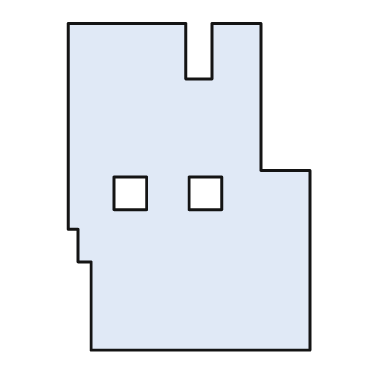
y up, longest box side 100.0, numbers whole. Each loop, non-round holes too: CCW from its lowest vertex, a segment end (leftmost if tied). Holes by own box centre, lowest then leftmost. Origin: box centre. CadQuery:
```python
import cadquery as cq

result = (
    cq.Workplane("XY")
    .moveTo(-30.0, -50.0)
    .lineTo(37.0, -50.0)
    .lineTo(37.0, 5.0)
    .lineTo(22.0, 5.0)
    .lineTo(22.0, 50.0)
    .lineTo(7.0, 50.0)
    .lineTo(7.0, 33.0)
    .lineTo(-1.0, 33.0)
    .lineTo(-1.0, 50.0)
    .lineTo(-37.0, 50.0)
    .lineTo(-37.0, -13.0)
    .lineTo(-34.0, -13.0)
    .lineTo(-34.0, -23.0)
    .lineTo(-30.0, -23.0)
    .close()
    .moveTo(-23.0, -7.0)
    .lineTo(-13.0, -7.0)
    .lineTo(-13.0, 3.0)
    .lineTo(-23.0, 3.0)
    .close()
    .moveTo(0.0, -7.0)
    .lineTo(10.0, -7.0)
    .lineTo(10.0, 3.0)
    .lineTo(0.0, 3.0)
    .close()
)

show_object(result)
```